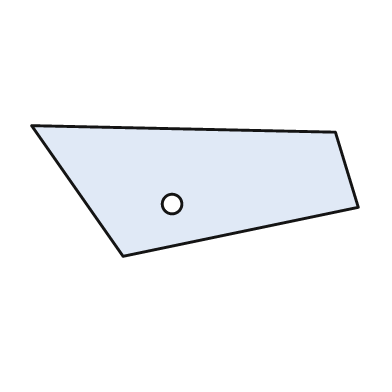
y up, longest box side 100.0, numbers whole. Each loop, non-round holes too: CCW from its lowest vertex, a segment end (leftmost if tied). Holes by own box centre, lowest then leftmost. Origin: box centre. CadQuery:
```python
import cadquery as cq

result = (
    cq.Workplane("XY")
    .moveTo(-22.0, -20.0)
    .lineTo(50.0, -5.0)
    .lineTo(43.0, 18.0)
    .lineTo(-50.0, 20.0)
    .close()
    .moveTo(-7.0, -4.0)
    .circle(3.0)
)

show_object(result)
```